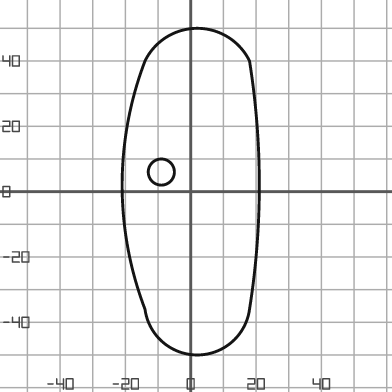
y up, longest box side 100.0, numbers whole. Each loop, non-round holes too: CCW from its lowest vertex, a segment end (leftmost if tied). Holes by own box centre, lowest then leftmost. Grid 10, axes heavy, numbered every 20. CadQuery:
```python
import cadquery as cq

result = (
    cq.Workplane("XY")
    .moveTo(-14.0, -36.0)
    .threePointArc((2.0, -50.0), (18.0, -36.0))
    .threePointArc((21.0, 2.0), (18.0, 40.0))
    .threePointArc((2.0, 50.0), (-14.0, 40.0))
    .threePointArc((-21.0, 2.0), (-14.0, -36.0))
    .close()
    .moveTo(-9.0, 6.0)
    .circle(4.0)
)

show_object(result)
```